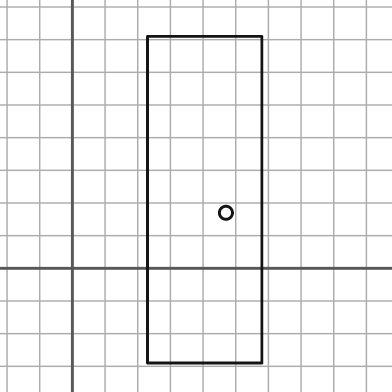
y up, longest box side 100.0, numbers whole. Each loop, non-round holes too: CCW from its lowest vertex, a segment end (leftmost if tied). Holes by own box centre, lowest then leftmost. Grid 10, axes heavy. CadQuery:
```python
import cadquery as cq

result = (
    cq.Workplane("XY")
    .moveTo(23.0, -29.0)
    .lineTo(58.0, -29.0)
    .lineTo(58.0, 71.0)
    .lineTo(23.0, 71.0)
    .close()
    .moveTo(47.0, 17.0)
    .circle(2.0)
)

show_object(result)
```